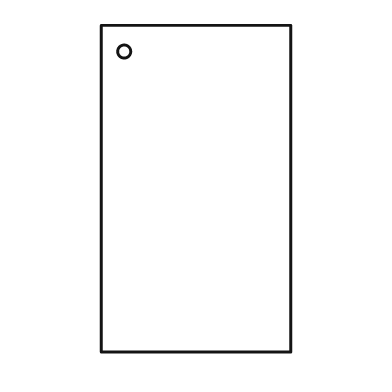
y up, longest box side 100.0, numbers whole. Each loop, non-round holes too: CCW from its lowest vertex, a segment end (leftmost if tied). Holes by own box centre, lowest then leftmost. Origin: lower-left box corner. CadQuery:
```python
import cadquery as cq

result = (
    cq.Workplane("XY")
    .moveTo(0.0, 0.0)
    .lineTo(58.0, 0.0)
    .lineTo(58.0, 100.0)
    .lineTo(0.0, 100.0)
    .close()
    .moveTo(7.0, 92.0)
    .circle(2.0)
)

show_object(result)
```